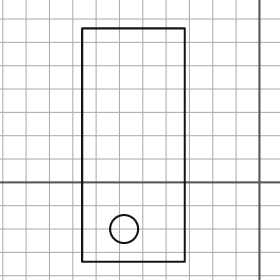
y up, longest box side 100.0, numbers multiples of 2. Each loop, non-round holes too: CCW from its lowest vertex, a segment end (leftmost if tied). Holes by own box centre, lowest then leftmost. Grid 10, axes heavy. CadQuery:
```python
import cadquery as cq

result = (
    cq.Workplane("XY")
    .moveTo(-76.0, -34.0)
    .lineTo(-32.0, -34.0)
    .lineTo(-32.0, 66.0)
    .lineTo(-76.0, 66.0)
    .close()
    .moveTo(-58.0, -20.0)
    .circle(6.0)
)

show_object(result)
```